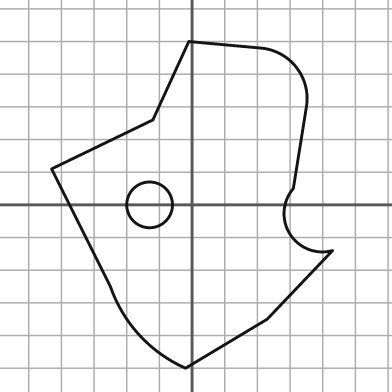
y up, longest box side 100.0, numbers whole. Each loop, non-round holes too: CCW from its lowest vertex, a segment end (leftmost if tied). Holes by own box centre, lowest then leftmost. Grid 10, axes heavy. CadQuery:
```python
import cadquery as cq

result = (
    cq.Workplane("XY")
    .moveTo(-2.0, -50.0)
    .lineTo(23.0, -35.0)
    .lineTo(43.0, -14.0)
    .threePointArc((30.0, -9.0), (31.0, 5.0))
    .lineTo(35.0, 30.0)
    .threePointArc((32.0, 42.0), (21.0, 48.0))
    .lineTo(-1.0, 50.0)
    .lineTo(-12.0, 26.0)
    .lineTo(-43.0, 11.0)
    .lineTo(-25.0, -25.0)
    .threePointArc((-16.0, -40.0), (-2.0, -50.0))
    .close()
    .moveTo(-13.0, 0.0)
    .circle(7.0)
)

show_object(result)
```